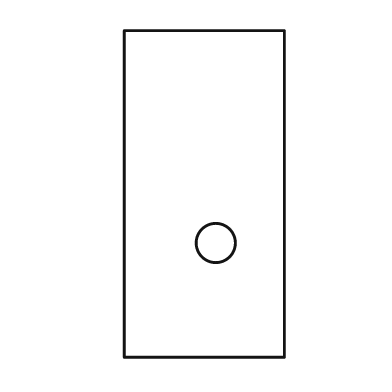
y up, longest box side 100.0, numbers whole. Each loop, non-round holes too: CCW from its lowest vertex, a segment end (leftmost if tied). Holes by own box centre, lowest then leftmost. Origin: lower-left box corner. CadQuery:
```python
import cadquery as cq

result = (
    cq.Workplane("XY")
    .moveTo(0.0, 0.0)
    .lineTo(49.0, 0.0)
    .lineTo(49.0, 100.0)
    .lineTo(0.0, 100.0)
    .close()
    .moveTo(28.0, 35.0)
    .circle(6.0)
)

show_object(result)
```